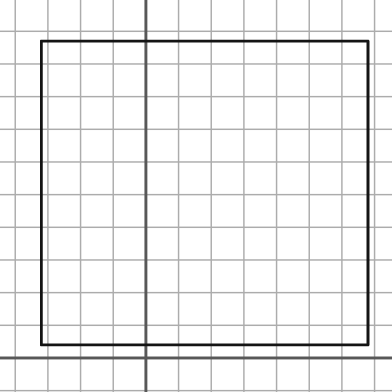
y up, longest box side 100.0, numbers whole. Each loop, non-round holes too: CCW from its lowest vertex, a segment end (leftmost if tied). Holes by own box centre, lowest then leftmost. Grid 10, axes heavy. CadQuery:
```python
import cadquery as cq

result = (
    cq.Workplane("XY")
    .moveTo(-32.0, 4.0)
    .lineTo(68.0, 4.0)
    .lineTo(68.0, 97.0)
    .lineTo(-32.0, 97.0)
    .close()
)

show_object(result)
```